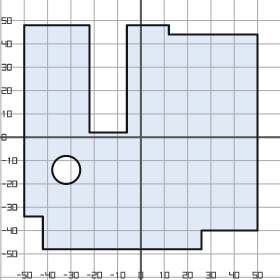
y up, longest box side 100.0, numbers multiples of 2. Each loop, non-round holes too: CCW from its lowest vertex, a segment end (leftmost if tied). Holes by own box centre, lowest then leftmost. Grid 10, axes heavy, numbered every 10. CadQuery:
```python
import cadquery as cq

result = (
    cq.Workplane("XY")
    .moveTo(-42.0, -48.0)
    .lineTo(26.0, -48.0)
    .lineTo(26.0, -40.0)
    .lineTo(50.0, -40.0)
    .lineTo(50.0, 44.0)
    .lineTo(12.0, 44.0)
    .lineTo(12.0, 48.0)
    .lineTo(-6.0, 48.0)
    .lineTo(-6.0, 2.0)
    .lineTo(-22.0, 2.0)
    .lineTo(-22.0, 48.0)
    .lineTo(-50.0, 48.0)
    .lineTo(-50.0, -34.0)
    .lineTo(-42.0, -34.0)
    .close()
    .moveTo(-32.0, -14.0)
    .circle(6.0)
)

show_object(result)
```